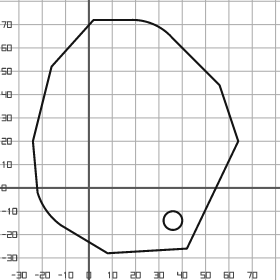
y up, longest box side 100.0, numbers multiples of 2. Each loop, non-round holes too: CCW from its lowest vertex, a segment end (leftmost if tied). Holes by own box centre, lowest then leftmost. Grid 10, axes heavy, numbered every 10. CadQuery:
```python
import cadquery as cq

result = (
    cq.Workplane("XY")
    .moveTo(8.0, -28.0)
    .lineTo(42.0, -26.0)
    .lineTo(64.0, 20.0)
    .lineTo(56.0, 44.0)
    .lineTo(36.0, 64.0)
    .threePointArc((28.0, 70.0), (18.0, 72.0))
    .lineTo(2.0, 72.0)
    .lineTo(-16.0, 52.0)
    .lineTo(-24.0, 20.0)
    .lineTo(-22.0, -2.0)
    .threePointArc((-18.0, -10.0), (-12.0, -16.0))
    .close()
    .moveTo(36.0, -14.0)
    .circle(4.0)
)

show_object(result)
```